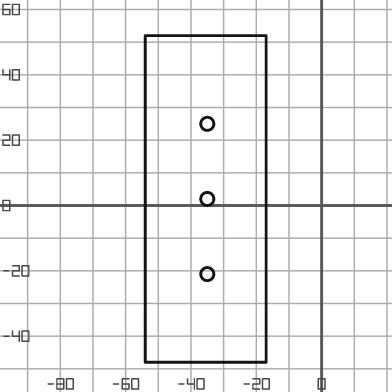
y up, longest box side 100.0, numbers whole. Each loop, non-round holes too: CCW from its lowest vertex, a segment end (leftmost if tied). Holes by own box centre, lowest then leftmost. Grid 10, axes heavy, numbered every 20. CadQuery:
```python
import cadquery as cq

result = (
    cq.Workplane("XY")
    .moveTo(-54.0, -48.0)
    .lineTo(-17.0, -48.0)
    .lineTo(-17.0, 52.0)
    .lineTo(-54.0, 52.0)
    .close()
    .moveTo(-35.0, -21.0)
    .circle(2.0)
    .moveTo(-35.0, 2.0)
    .circle(2.0)
    .moveTo(-35.0, 25.0)
    .circle(2.0)
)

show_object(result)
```